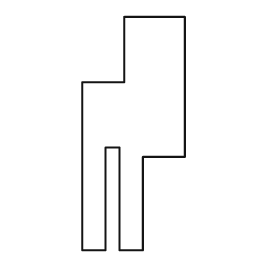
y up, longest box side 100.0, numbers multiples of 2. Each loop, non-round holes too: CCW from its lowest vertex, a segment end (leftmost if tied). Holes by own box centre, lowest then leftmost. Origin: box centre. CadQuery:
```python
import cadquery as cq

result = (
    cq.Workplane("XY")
    .moveTo(-22.0, -50.0)
    .lineTo(-12.0, -50.0)
    .lineTo(-12.0, -6.0)
    .lineTo(-6.0, -6.0)
    .lineTo(-6.0, -50.0)
    .lineTo(4.0, -50.0)
    .lineTo(4.0, -10.0)
    .lineTo(22.0, -10.0)
    .lineTo(22.0, 50.0)
    .lineTo(-4.0, 50.0)
    .lineTo(-4.0, 22.0)
    .lineTo(-22.0, 22.0)
    .close()
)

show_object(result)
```